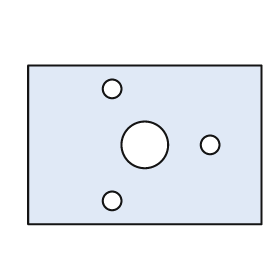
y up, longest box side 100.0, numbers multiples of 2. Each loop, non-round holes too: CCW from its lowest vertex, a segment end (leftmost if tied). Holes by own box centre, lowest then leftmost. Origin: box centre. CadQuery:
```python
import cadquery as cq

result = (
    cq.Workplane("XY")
    .moveTo(-50.0, -34.0)
    .lineTo(50.0, -34.0)
    .lineTo(50.0, 34.0)
    .lineTo(-50.0, 34.0)
    .close()
    .moveTo(-14.0, -24.0)
    .circle(4.0)
    .moveTo(0.0, 0.0)
    .circle(10.0)
    .moveTo(28.0, 0.0)
    .circle(4.0)
    .moveTo(-14.0, 24.0)
    .circle(4.0)
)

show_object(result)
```